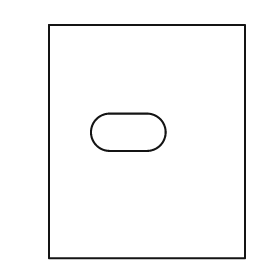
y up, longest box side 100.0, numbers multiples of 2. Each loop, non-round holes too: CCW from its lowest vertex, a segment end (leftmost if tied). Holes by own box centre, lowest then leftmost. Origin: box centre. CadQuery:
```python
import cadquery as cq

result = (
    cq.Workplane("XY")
    .moveTo(-42.0, -50.0)
    .lineTo(42.0, -50.0)
    .lineTo(42.0, 50.0)
    .lineTo(-42.0, 50.0)
    .close()
    .moveTo(-16.0, -4.0)
    .lineTo(0.0, -4.0)
    .threePointArc((8.0, 4.0), (0.0, 12.0))
    .lineTo(-16.0, 12.0)
    .threePointArc((-24.0, 4.0), (-16.0, -4.0))
    .close()
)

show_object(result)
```